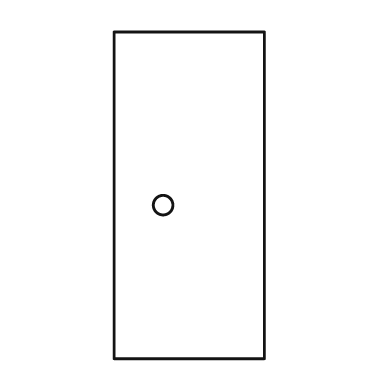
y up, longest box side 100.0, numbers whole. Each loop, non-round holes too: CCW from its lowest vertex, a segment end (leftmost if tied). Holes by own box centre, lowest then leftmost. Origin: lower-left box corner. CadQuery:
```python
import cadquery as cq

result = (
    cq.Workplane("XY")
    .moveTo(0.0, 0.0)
    .lineTo(46.0, 0.0)
    .lineTo(46.0, 100.0)
    .lineTo(0.0, 100.0)
    .close()
    .moveTo(15.0, 47.0)
    .circle(3.0)
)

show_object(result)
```